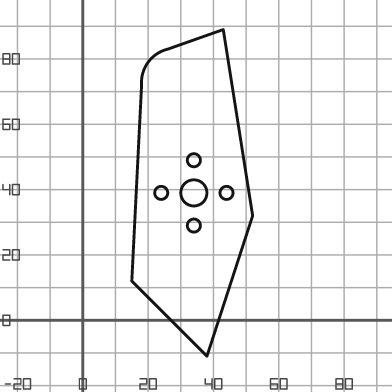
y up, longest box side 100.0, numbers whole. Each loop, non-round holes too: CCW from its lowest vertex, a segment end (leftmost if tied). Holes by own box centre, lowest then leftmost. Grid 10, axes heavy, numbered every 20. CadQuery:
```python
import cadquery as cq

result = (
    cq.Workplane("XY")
    .moveTo(38.0, -11.0)
    .lineTo(52.0, 32.0)
    .lineTo(43.0, 89.0)
    .lineTo(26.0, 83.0)
    .threePointArc((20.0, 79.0), (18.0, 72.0))
    .lineTo(15.0, 12.0)
    .close()
    .moveTo(34.0, 29.0)
    .circle(2.0)
    .moveTo(24.0, 39.0)
    .circle(2.0)
    .moveTo(34.0, 39.0)
    .circle(4.0)
    .moveTo(44.0, 39.0)
    .circle(2.0)
    .moveTo(34.0, 49.0)
    .circle(2.0)
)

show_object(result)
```